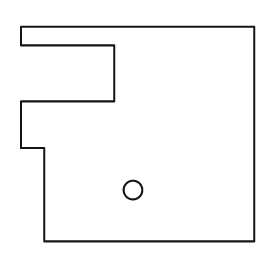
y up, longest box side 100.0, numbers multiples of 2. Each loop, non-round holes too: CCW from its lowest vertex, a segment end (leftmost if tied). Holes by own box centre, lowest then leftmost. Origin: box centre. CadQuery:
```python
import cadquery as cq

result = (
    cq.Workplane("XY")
    .moveTo(-40.0, -46.0)
    .lineTo(50.0, -46.0)
    .lineTo(50.0, 46.0)
    .lineTo(-50.0, 46.0)
    .lineTo(-50.0, 38.0)
    .lineTo(-10.0, 38.0)
    .lineTo(-10.0, 14.0)
    .lineTo(-50.0, 14.0)
    .lineTo(-50.0, -6.0)
    .lineTo(-40.0, -6.0)
    .close()
    .moveTo(-2.0, -24.0)
    .circle(4.0)
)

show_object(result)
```